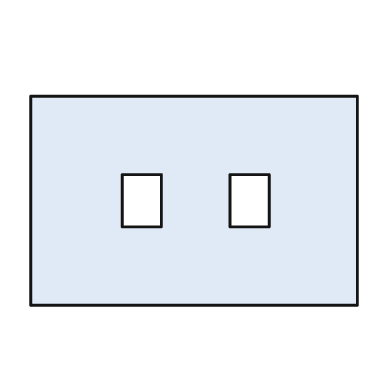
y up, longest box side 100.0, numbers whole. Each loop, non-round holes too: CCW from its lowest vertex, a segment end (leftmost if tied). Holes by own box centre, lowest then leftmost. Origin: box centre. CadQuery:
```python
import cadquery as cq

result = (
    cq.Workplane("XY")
    .moveTo(-50.0, -32.0)
    .lineTo(50.0, -32.0)
    .lineTo(50.0, 32.0)
    .lineTo(-50.0, 32.0)
    .close()
    .moveTo(-22.0, -8.0)
    .lineTo(-10.0, -8.0)
    .lineTo(-10.0, 8.0)
    .lineTo(-22.0, 8.0)
    .close()
    .moveTo(11.0, -8.0)
    .lineTo(23.0, -8.0)
    .lineTo(23.0, 8.0)
    .lineTo(11.0, 8.0)
    .close()
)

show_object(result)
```